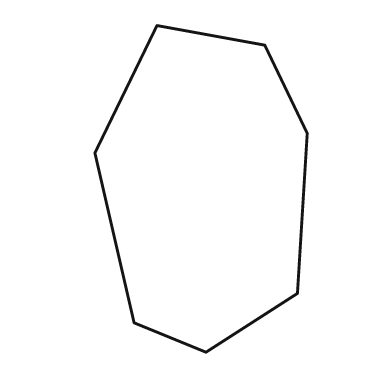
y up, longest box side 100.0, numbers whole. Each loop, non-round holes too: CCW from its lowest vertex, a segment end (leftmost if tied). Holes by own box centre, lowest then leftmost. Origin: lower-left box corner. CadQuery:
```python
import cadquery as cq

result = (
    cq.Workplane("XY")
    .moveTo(34.0, 0.0)
    .lineTo(62.0, 18.0)
    .lineTo(65.0, 67.0)
    .lineTo(52.0, 94.0)
    .lineTo(19.0, 100.0)
    .lineTo(0.0, 61.0)
    .lineTo(12.0, 9.0)
    .close()
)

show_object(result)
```